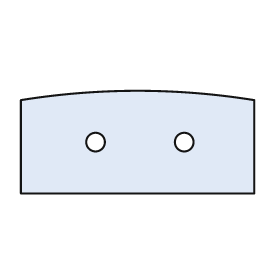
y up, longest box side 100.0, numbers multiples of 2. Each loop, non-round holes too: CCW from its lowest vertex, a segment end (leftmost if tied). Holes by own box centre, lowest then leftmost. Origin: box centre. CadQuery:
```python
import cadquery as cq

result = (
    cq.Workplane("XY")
    .moveTo(-50.0, -22.0)
    .lineTo(50.0, -22.0)
    .lineTo(50.0, 18.0)
    .threePointArc((0.0, 22.0), (-50.0, 18.0))
    .close()
    .moveTo(-18.0, 0.0)
    .circle(4.0)
    .moveTo(20.0, 0.0)
    .circle(4.0)
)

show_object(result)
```